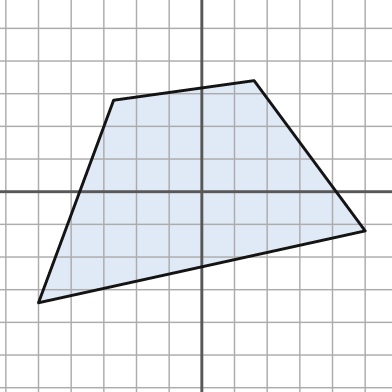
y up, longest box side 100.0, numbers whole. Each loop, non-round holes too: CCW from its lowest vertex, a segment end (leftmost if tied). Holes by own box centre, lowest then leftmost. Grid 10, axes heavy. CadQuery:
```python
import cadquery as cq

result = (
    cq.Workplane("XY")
    .moveTo(-50.0, -34.0)
    .lineTo(50.0, -12.0)
    .lineTo(16.0, 34.0)
    .lineTo(-27.0, 28.0)
    .close()
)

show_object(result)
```